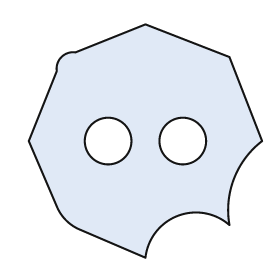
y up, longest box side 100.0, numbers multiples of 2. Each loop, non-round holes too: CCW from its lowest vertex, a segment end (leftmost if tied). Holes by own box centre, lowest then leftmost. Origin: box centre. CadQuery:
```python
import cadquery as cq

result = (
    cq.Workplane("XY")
    .moveTo(0.0, -50.0)
    .threePointArc((14.0, -32.0), (36.0, -36.0))
    .threePointArc((38.0, -16.0), (50.0, 0.0))
    .lineTo(36.0, 36.0)
    .lineTo(0.0, 50.0)
    .lineTo(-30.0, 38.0)
    .threePointArc((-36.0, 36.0), (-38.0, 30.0))
    .lineTo(-50.0, 0.0)
    .lineTo(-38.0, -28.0)
    .threePointArc((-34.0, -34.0), (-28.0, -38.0))
    .close()
    .moveTo(-16.0, 0.0)
    .circle(10.0)
    .moveTo(16.0, 0.0)
    .circle(10.0)
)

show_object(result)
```